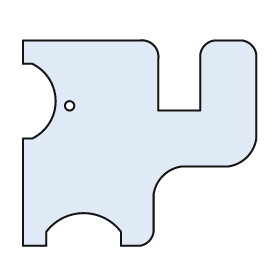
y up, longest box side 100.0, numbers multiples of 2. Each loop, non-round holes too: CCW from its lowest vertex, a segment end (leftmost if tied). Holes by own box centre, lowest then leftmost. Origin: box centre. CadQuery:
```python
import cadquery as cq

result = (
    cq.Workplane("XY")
    .moveTo(-50.0, -44.0)
    .lineTo(-40.0, -44.0)
    .lineTo(-40.0, -38.0)
    .threePointArc((-24.0, -30.0), (-8.0, -38.0))
    .lineTo(-8.0, -44.0)
    .lineTo(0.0, -44.0)
    .threePointArc((4.0, -42.0), (6.0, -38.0))
    .lineTo(6.0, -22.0)
    .threePointArc((10.0, -14.0), (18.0, -10.0))
    .lineTo(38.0, -10.0)
    .threePointArc((46.0, -6.0), (50.0, 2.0))
    .lineTo(50.0, 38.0)
    .threePointArc((48.0, 42.0), (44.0, 44.0))
    .lineTo(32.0, 44.0)
    .threePointArc((28.0, 42.0), (26.0, 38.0))
    .lineTo(26.0, 14.0)
    .lineTo(8.0, 14.0)
    .lineTo(8.0, 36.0)
    .threePointArc((6.0, 42.0), (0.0, 44.0))
    .lineTo(-50.0, 44.0)
    .lineTo(-50.0, 34.0)
    .lineTo(-46.0, 34.0)
    .threePointArc((-36.0, 18.0), (-46.0, 2.0))
    .lineTo(-50.0, 2.0)
    .close()
    .moveTo(-30.0, 16.0)
    .circle(2.0)
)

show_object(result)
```